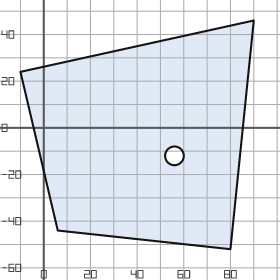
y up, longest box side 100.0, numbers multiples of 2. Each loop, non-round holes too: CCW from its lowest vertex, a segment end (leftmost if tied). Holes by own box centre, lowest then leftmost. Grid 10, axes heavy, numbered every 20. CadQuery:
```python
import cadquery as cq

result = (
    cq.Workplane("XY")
    .moveTo(80.0, -52.0)
    .lineTo(90.0, 46.0)
    .lineTo(-10.0, 24.0)
    .lineTo(6.0, -44.0)
    .close()
    .moveTo(56.0, -12.0)
    .circle(4.0)
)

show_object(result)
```